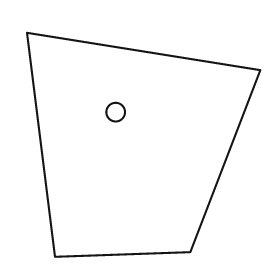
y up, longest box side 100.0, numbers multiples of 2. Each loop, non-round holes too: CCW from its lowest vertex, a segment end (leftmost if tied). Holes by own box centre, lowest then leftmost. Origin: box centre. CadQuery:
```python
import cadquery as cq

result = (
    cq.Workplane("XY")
    .moveTo(-38.0, -48.0)
    .lineTo(20.0, -46.0)
    .lineTo(50.0, 32.0)
    .lineTo(-50.0, 48.0)
    .close()
    .moveTo(-12.0, 14.0)
    .circle(4.0)
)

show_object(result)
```